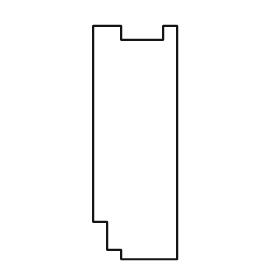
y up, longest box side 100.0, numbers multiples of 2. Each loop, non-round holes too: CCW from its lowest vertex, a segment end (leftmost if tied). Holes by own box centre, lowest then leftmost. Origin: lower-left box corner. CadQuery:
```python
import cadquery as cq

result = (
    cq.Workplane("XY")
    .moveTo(12.0, 0.0)
    .lineTo(36.0, 0.0)
    .lineTo(36.0, 100.0)
    .lineTo(30.0, 100.0)
    .lineTo(30.0, 94.0)
    .lineTo(12.0, 94.0)
    .lineTo(12.0, 100.0)
    .lineTo(0.0, 100.0)
    .lineTo(0.0, 16.0)
    .lineTo(6.0, 16.0)
    .lineTo(6.0, 4.0)
    .lineTo(12.0, 4.0)
    .close()
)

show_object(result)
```